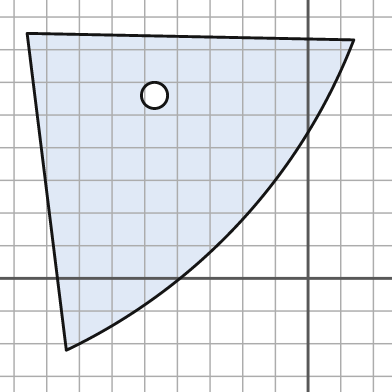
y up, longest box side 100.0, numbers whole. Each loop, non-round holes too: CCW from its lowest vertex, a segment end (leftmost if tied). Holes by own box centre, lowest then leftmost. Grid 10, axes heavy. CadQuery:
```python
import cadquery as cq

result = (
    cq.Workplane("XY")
    .moveTo(-74.0, -22.0)
    .threePointArc((-21.0, 17.0), (14.0, 73.0))
    .lineTo(-86.0, 75.0)
    .close()
    .moveTo(-47.0, 56.0)
    .circle(4.0)
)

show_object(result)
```